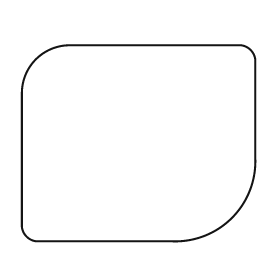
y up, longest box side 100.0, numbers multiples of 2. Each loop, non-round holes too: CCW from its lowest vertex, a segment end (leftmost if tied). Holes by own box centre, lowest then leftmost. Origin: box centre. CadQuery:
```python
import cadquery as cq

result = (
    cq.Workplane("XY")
    .moveTo(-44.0, -42.0)
    .lineTo(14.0, -42.0)
    .threePointArc((40.0, -32.0), (50.0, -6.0))
    .lineTo(50.0, 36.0)
    .threePointArc((48.0, 40.0), (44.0, 42.0))
    .lineTo(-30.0, 42.0)
    .threePointArc((-44.0, 36.0), (-50.0, 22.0))
    .lineTo(-50.0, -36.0)
    .threePointArc((-48.0, -40.0), (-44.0, -42.0))
    .close()
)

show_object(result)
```